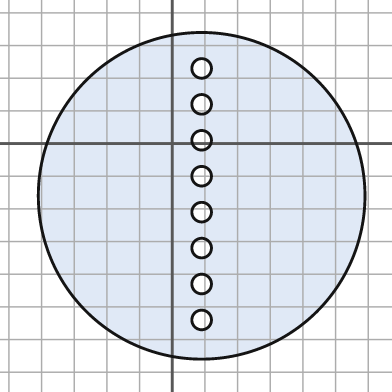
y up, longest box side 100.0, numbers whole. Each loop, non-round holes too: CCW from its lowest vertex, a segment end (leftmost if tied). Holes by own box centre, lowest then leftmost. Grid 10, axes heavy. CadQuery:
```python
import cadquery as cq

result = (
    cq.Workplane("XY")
    .moveTo(9.0, -16.0)
    .circle(50.0)
    .moveTo(9.0, -54.0)
    .circle(3.0)
    .moveTo(9.0, -43.0)
    .circle(3.0)
    .moveTo(9.0, -32.0)
    .circle(3.0)
    .moveTo(9.0, -21.0)
    .circle(3.0)
    .moveTo(9.0, -10.0)
    .circle(3.0)
    .moveTo(9.0, 1.0)
    .circle(3.0)
    .moveTo(9.0, 12.0)
    .circle(3.0)
    .moveTo(9.0, 23.0)
    .circle(3.0)
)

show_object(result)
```